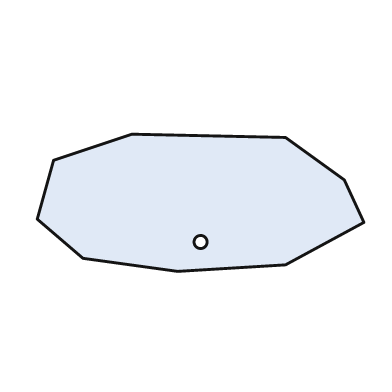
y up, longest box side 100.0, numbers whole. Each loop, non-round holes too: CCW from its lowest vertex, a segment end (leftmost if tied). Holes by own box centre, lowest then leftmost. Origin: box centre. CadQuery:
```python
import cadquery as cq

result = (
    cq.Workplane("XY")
    .moveTo(-7.0, -21.0)
    .lineTo(26.0, -19.0)
    .lineTo(50.0, -6.0)
    .lineTo(44.0, 7.0)
    .lineTo(26.0, 20.0)
    .lineTo(-21.0, 21.0)
    .lineTo(-45.0, 13.0)
    .lineTo(-50.0, -5.0)
    .lineTo(-36.0, -17.0)
    .close()
    .moveTo(0.0, -12.0)
    .circle(2.0)
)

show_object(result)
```